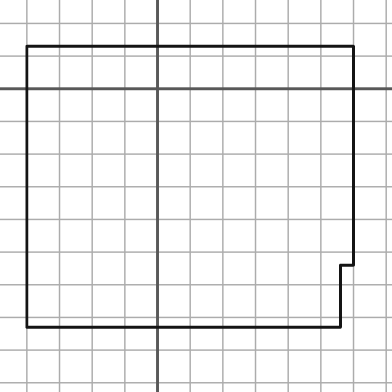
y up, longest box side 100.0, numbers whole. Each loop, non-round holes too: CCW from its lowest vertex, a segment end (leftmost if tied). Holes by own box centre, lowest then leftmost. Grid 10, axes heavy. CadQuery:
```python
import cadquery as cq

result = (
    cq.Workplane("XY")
    .moveTo(-40.0, -73.0)
    .lineTo(56.0, -73.0)
    .lineTo(56.0, -54.0)
    .lineTo(60.0, -54.0)
    .lineTo(60.0, 13.0)
    .lineTo(-40.0, 13.0)
    .close()
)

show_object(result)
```